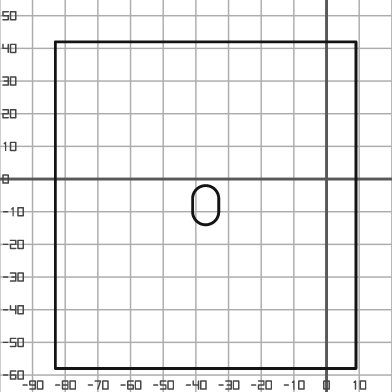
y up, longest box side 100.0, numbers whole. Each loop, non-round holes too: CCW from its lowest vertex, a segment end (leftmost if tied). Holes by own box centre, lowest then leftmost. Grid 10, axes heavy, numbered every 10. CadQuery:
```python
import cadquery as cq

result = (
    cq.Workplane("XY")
    .moveTo(-83.0, -58.0)
    .lineTo(9.0, -58.0)
    .lineTo(9.0, 42.0)
    .lineTo(-83.0, 42.0)
    .close()
    .moveTo(-41.0, -10.0)
    .threePointArc((-37.0, -14.0), (-33.0, -10.0))
    .lineTo(-33.0, -6.0)
    .threePointArc((-37.0, -2.0), (-41.0, -6.0))
    .close()
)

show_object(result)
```